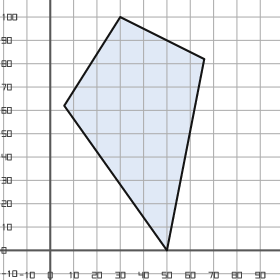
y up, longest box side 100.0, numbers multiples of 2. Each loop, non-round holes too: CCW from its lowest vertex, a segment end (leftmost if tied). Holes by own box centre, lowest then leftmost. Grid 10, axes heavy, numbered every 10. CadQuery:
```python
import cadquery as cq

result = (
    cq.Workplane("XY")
    .moveTo(50.0, 0.0)
    .lineTo(66.0, 82.0)
    .lineTo(30.0, 100.0)
    .lineTo(6.0, 62.0)
    .close()
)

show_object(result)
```